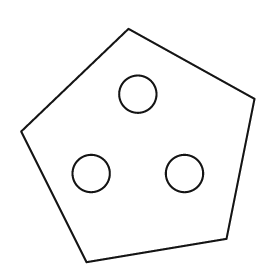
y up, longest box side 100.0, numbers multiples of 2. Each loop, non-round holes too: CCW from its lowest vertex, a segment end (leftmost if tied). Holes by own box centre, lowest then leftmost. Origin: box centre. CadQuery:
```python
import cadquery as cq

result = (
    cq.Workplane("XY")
    .moveTo(-22.0, -50.0)
    .lineTo(38.0, -40.0)
    .lineTo(50.0, 20.0)
    .lineTo(-4.0, 50.0)
    .lineTo(-50.0, 6.0)
    .close()
    .moveTo(-20.0, -12.0)
    .circle(8.0)
    .moveTo(20.0, -12.0)
    .circle(8.0)
    .moveTo(0.0, 22.0)
    .circle(8.0)
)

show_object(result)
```